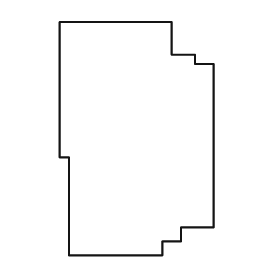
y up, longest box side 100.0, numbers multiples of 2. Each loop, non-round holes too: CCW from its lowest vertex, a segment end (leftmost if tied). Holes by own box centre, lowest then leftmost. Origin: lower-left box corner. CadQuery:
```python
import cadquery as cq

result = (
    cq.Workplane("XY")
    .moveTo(4.0, 0.0)
    .lineTo(44.0, 0.0)
    .lineTo(44.0, 6.0)
    .lineTo(52.0, 6.0)
    .lineTo(52.0, 12.0)
    .lineTo(66.0, 12.0)
    .lineTo(66.0, 82.0)
    .lineTo(58.0, 82.0)
    .lineTo(58.0, 86.0)
    .lineTo(48.0, 86.0)
    .lineTo(48.0, 100.0)
    .lineTo(0.0, 100.0)
    .lineTo(0.0, 42.0)
    .lineTo(4.0, 42.0)
    .close()
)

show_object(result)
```